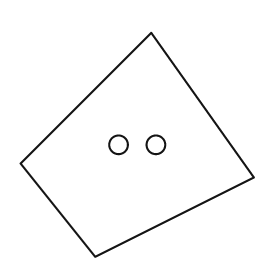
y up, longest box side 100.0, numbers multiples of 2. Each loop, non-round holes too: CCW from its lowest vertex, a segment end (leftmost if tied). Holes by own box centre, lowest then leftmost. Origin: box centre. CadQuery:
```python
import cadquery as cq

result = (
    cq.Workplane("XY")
    .moveTo(-18.0, -48.0)
    .lineTo(50.0, -14.0)
    .lineTo(6.0, 48.0)
    .lineTo(-50.0, -8.0)
    .close()
    .moveTo(-8.0, 0.0)
    .circle(4.0)
    .moveTo(8.0, 0.0)
    .circle(4.0)
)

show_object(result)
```